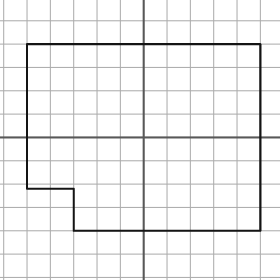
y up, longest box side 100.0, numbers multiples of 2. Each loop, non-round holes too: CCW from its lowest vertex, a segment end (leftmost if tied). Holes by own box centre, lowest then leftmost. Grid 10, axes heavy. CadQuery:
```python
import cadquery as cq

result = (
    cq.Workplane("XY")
    .moveTo(-30.0, -40.0)
    .lineTo(50.0, -40.0)
    .lineTo(50.0, 40.0)
    .lineTo(-50.0, 40.0)
    .lineTo(-50.0, -22.0)
    .lineTo(-30.0, -22.0)
    .close()
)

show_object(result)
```